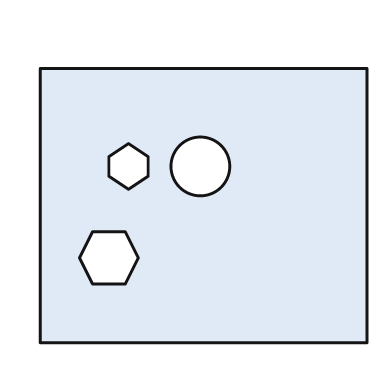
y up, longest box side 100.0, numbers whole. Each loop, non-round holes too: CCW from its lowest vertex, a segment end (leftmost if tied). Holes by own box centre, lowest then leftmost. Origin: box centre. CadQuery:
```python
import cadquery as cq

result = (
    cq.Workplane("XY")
    .moveTo(-50.0, -42.0)
    .lineTo(50.0, -42.0)
    .lineTo(50.0, 42.0)
    .lineTo(-50.0, 42.0)
    .close()
    .moveTo(-34.0, -24.0)
    .lineTo(-24.0, -24.0)
    .lineTo(-20.0, -16.0)
    .lineTo(-24.0, -8.0)
    .lineTo(-34.0, -8.0)
    .lineTo(-38.0, -16.0)
    .close()
    .moveTo(-23.0, 5.0)
    .lineTo(-17.0, 9.0)
    .lineTo(-17.0, 15.0)
    .lineTo(-23.0, 19.0)
    .lineTo(-29.0, 15.0)
    .lineTo(-29.0, 9.0)
    .close()
    .moveTo(-1.0, 12.0)
    .circle(9.0)
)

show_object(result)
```